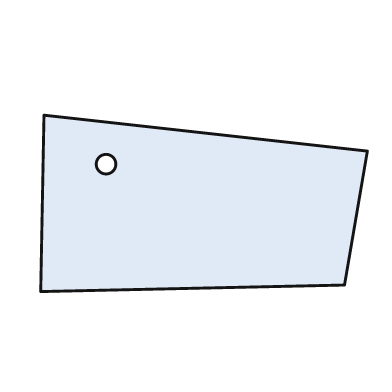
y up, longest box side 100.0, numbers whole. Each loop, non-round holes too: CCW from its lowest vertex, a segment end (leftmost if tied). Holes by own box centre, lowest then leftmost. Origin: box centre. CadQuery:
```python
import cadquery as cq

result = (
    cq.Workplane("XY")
    .moveTo(-50.0, -27.0)
    .lineTo(43.0, -25.0)
    .lineTo(50.0, 16.0)
    .lineTo(-49.0, 27.0)
    .close()
    .moveTo(-30.0, 12.0)
    .circle(3.0)
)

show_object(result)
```